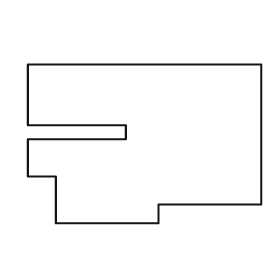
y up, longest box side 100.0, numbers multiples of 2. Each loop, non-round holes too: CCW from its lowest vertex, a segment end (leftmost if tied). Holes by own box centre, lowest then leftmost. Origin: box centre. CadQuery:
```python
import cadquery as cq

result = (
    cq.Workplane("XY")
    .moveTo(-38.0, -34.0)
    .lineTo(6.0, -34.0)
    .lineTo(6.0, -26.0)
    .lineTo(50.0, -26.0)
    .lineTo(50.0, 34.0)
    .lineTo(-50.0, 34.0)
    .lineTo(-50.0, 8.0)
    .lineTo(-8.0, 8.0)
    .lineTo(-8.0, 2.0)
    .lineTo(-50.0, 2.0)
    .lineTo(-50.0, -14.0)
    .lineTo(-38.0, -14.0)
    .close()
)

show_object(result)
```